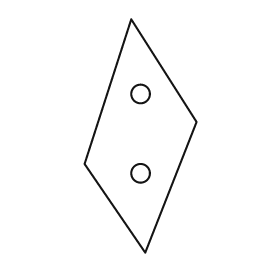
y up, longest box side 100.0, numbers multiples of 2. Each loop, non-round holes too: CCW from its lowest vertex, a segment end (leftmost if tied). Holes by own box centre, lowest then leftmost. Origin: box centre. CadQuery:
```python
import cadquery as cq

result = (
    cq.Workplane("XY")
    .moveTo(2.0, -50.0)
    .lineTo(24.0, 6.0)
    .lineTo(-4.0, 50.0)
    .lineTo(-24.0, -12.0)
    .close()
    .moveTo(0.0, -16.0)
    .circle(4.0)
    .moveTo(0.0, 18.0)
    .circle(4.0)
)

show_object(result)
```